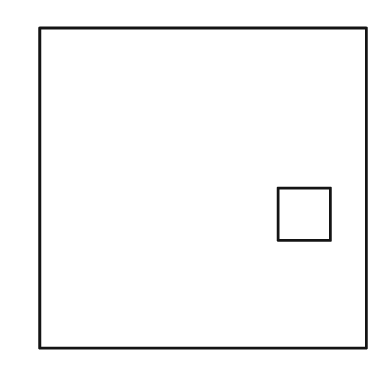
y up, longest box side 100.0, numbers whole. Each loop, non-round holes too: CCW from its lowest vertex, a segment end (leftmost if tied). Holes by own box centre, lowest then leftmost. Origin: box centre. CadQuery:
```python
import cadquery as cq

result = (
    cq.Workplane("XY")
    .moveTo(-50.0, -49.0)
    .lineTo(50.0, -49.0)
    .lineTo(50.0, 49.0)
    .lineTo(-50.0, 49.0)
    .close()
    .moveTo(23.0, -16.0)
    .lineTo(39.0, -16.0)
    .lineTo(39.0, 0.0)
    .lineTo(23.0, 0.0)
    .close()
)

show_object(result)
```